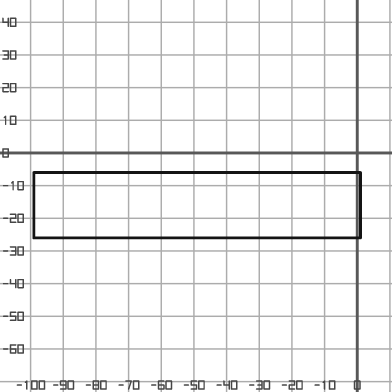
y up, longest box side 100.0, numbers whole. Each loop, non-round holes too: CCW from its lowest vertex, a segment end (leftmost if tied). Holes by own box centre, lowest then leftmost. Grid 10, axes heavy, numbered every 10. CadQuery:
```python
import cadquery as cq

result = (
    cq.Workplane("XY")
    .moveTo(-99.0, -26.0)
    .lineTo(1.0, -26.0)
    .lineTo(1.0, -6.0)
    .lineTo(-99.0, -6.0)
    .close()
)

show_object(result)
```